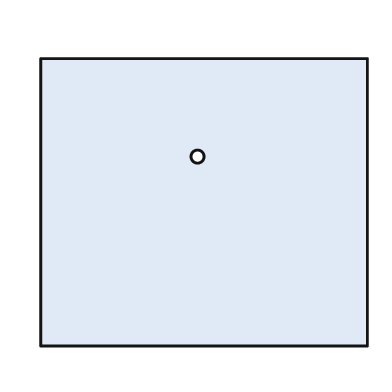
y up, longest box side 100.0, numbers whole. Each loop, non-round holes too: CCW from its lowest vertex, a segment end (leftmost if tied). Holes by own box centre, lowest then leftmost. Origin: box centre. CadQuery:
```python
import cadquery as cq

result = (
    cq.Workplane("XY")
    .moveTo(-50.0, -44.0)
    .lineTo(50.0, -44.0)
    .lineTo(50.0, 44.0)
    .lineTo(-50.0, 44.0)
    .close()
    .moveTo(-2.0, 14.0)
    .circle(2.0)
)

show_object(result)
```